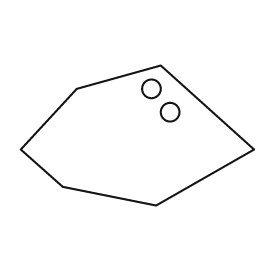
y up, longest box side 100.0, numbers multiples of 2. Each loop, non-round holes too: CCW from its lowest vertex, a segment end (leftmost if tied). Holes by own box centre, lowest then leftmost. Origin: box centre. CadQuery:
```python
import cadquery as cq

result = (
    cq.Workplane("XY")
    .moveTo(8.0, -30.0)
    .lineTo(50.0, -6.0)
    .lineTo(10.0, 30.0)
    .lineTo(-26.0, 20.0)
    .lineTo(-50.0, -6.0)
    .lineTo(-32.0, -22.0)
    .close()
    .moveTo(14.0, 10.0)
    .circle(4.0)
    .moveTo(6.0, 20.0)
    .circle(4.0)
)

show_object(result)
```